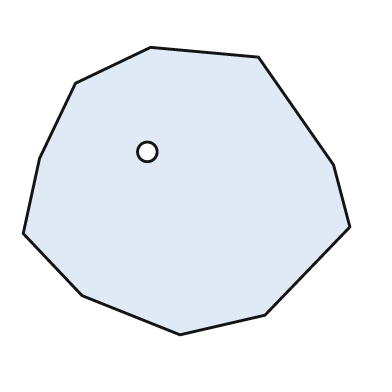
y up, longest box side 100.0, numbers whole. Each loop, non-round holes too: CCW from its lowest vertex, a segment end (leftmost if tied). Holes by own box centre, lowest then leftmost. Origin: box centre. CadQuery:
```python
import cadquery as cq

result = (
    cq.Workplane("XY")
    .moveTo(-2.0, -44.0)
    .lineTo(24.0, -38.0)
    .lineTo(50.0, -11.0)
    .lineTo(45.0, 8.0)
    .lineTo(22.0, 41.0)
    .lineTo(-11.0, 44.0)
    .lineTo(-34.0, 33.0)
    .lineTo(-45.0, 10.0)
    .lineTo(-50.0, -13.0)
    .lineTo(-32.0, -32.0)
    .close()
    .moveTo(-12.0, 12.0)
    .circle(3.0)
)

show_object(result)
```